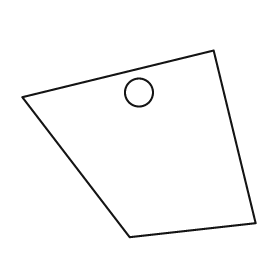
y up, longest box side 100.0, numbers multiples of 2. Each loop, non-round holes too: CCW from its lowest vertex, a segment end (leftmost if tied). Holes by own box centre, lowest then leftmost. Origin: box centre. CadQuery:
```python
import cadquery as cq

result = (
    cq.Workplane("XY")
    .moveTo(-4.0, -40.0)
    .lineTo(50.0, -34.0)
    .lineTo(32.0, 40.0)
    .lineTo(-50.0, 20.0)
    .close()
    .moveTo(0.0, 22.0)
    .circle(6.0)
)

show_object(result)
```